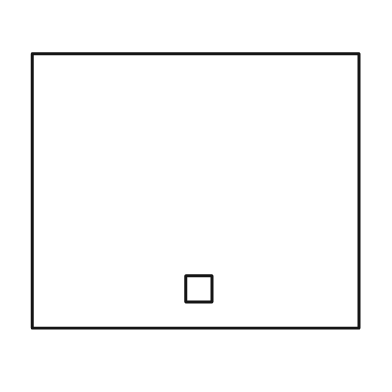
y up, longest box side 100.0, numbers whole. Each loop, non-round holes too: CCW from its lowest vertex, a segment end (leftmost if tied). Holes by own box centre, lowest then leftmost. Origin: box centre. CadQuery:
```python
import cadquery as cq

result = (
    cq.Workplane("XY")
    .moveTo(-50.0, -42.0)
    .lineTo(50.0, -42.0)
    .lineTo(50.0, 42.0)
    .lineTo(-50.0, 42.0)
    .close()
    .moveTo(-3.0, -34.0)
    .lineTo(5.0, -34.0)
    .lineTo(5.0, -26.0)
    .lineTo(-3.0, -26.0)
    .close()
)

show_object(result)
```